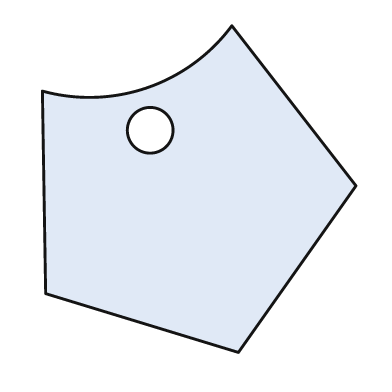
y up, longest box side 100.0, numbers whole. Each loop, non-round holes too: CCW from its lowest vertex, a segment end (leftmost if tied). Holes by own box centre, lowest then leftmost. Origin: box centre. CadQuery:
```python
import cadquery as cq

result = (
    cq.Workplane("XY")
    .moveTo(12.0, -50.0)
    .lineTo(48.0, 1.0)
    .lineTo(10.0, 50.0)
    .threePointArc((-16.0, 31.0), (-48.0, 30.0))
    .lineTo(-47.0, -32.0)
    .close()
    .moveTo(-15.0, 18.0)
    .circle(7.0)
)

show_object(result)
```